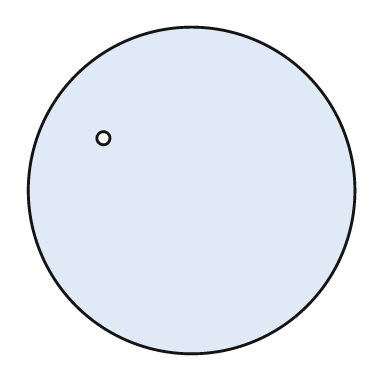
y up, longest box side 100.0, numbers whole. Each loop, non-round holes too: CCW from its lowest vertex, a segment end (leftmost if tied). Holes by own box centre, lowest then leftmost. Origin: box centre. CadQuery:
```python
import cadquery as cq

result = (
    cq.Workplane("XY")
    .moveTo(0.0, 0.0)
    .circle(50.0)
    .moveTo(-27.0, 16.0)
    .circle(2.0)
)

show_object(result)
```